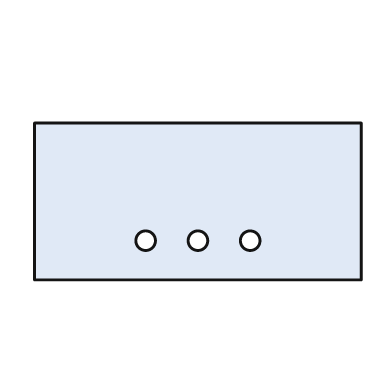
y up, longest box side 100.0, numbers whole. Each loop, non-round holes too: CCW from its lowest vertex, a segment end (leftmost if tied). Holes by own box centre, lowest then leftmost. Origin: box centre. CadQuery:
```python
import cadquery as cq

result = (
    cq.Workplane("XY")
    .moveTo(-50.0, -24.0)
    .lineTo(50.0, -24.0)
    .lineTo(50.0, 24.0)
    .lineTo(-50.0, 24.0)
    .close()
    .moveTo(-16.0, -12.0)
    .circle(3.0)
    .moveTo(0.0, -12.0)
    .circle(3.0)
    .moveTo(16.0, -12.0)
    .circle(3.0)
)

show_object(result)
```